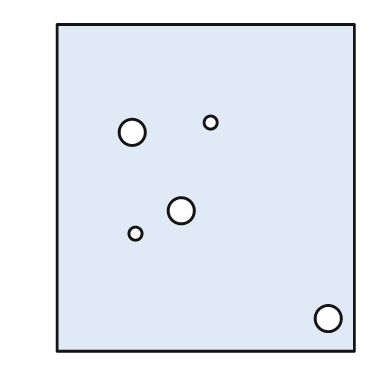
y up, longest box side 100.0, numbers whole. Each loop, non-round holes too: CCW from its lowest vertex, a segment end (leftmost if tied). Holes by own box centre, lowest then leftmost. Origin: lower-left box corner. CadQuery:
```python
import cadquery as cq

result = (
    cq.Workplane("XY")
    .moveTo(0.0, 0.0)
    .lineTo(91.0, 0.0)
    .lineTo(91.0, 100.0)
    .lineTo(0.0, 100.0)
    .close()
    .moveTo(83.0, 10.0)
    .circle(4.0)
    .moveTo(24.0, 36.0)
    .circle(2.0)
    .moveTo(38.0, 43.0)
    .circle(4.0)
    .moveTo(23.0, 67.0)
    .circle(4.0)
    .moveTo(47.0, 70.0)
    .circle(2.0)
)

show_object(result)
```